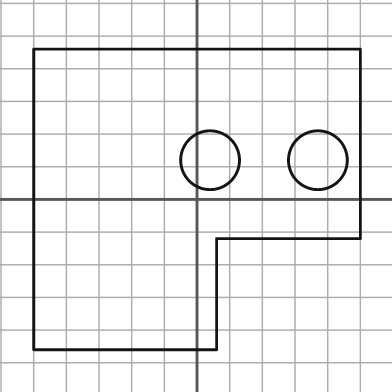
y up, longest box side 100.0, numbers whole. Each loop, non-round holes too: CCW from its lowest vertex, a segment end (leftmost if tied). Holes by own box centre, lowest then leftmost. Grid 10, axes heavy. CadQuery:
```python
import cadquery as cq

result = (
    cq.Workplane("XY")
    .moveTo(-50.0, -46.0)
    .lineTo(6.0, -46.0)
    .lineTo(6.0, -12.0)
    .lineTo(50.0, -12.0)
    .lineTo(50.0, 46.0)
    .lineTo(-50.0, 46.0)
    .close()
    .moveTo(4.0, 12.0)
    .circle(9.0)
    .moveTo(37.0, 12.0)
    .circle(9.0)
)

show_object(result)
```